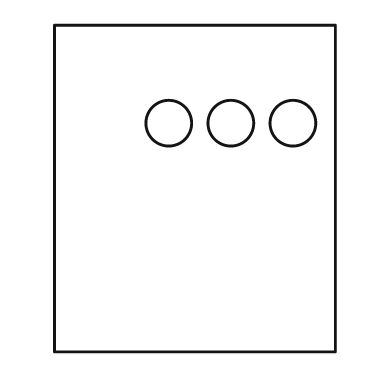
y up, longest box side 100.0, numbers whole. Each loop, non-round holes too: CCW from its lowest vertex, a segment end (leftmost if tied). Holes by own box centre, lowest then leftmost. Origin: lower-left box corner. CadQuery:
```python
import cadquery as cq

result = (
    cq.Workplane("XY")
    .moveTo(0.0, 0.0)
    .lineTo(86.0, 0.0)
    .lineTo(86.0, 100.0)
    .lineTo(0.0, 100.0)
    .close()
    .moveTo(35.0, 70.0)
    .circle(7.0)
    .moveTo(54.0, 70.0)
    .circle(7.0)
    .moveTo(73.0, 70.0)
    .circle(7.0)
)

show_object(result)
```